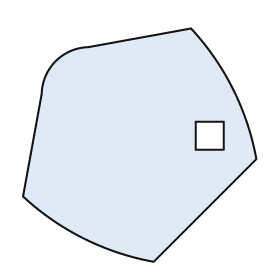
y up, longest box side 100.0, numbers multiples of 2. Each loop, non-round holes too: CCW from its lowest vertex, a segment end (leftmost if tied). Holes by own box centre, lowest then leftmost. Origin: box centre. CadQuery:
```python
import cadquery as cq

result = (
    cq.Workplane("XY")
    .moveTo(6.0, -50.0)
    .lineTo(50.0, -6.0)
    .threePointArc((40.0, 24.0), (22.0, 50.0))
    .lineTo(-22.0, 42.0)
    .threePointArc((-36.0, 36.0), (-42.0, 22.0))
    .lineTo(-50.0, -22.0)
    .threePointArc((-24.0, -40.0), (6.0, -50.0))
    .close()
    .moveTo(24.0, -2.0)
    .lineTo(36.0, -2.0)
    .lineTo(36.0, 10.0)
    .lineTo(24.0, 10.0)
    .close()
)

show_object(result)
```